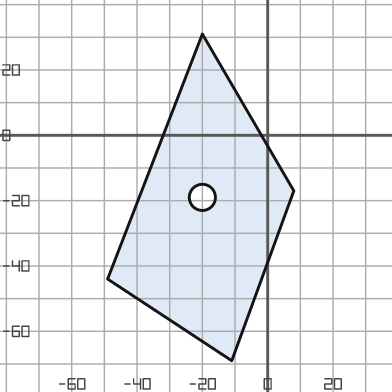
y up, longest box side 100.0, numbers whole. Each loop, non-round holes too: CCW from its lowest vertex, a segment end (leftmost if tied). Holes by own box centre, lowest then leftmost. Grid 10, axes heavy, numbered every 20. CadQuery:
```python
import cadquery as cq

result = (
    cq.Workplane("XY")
    .moveTo(-11.0, -69.0)
    .lineTo(8.0, -17.0)
    .lineTo(-20.0, 31.0)
    .lineTo(-49.0, -44.0)
    .close()
    .moveTo(-20.0, -19.0)
    .circle(4.0)
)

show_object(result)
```